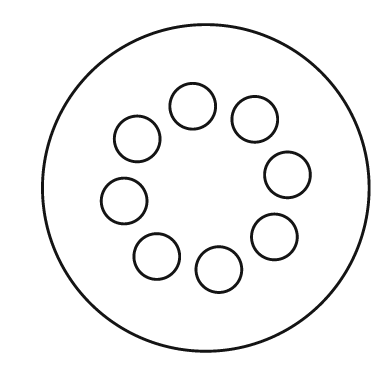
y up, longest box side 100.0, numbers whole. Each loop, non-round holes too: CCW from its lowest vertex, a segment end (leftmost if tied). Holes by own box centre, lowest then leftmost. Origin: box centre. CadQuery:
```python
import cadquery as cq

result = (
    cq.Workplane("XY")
    .moveTo(0.0, 0.0)
    .circle(50.0)
    .moveTo(4.0, -25.0)
    .circle(7.0)
    .moveTo(-15.0, -21.0)
    .circle(7.0)
    .moveTo(21.0, -15.0)
    .circle(7.0)
    .moveTo(-25.0, -4.0)
    .circle(7.0)
    .moveTo(25.0, 4.0)
    .circle(7.0)
    .moveTo(-21.0, 15.0)
    .circle(7.0)
    .moveTo(15.0, 21.0)
    .circle(7.0)
    .moveTo(-4.0, 25.0)
    .circle(7.0)
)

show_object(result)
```